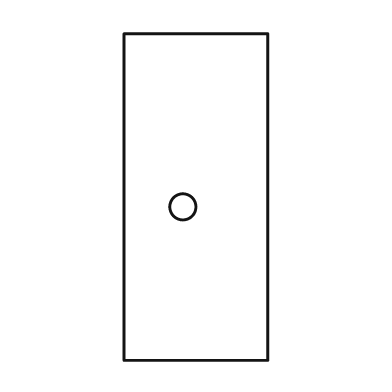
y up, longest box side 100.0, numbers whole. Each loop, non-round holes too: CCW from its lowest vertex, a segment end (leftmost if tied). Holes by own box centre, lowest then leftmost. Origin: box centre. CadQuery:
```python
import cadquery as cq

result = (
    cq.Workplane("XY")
    .moveTo(-22.0, -50.0)
    .lineTo(22.0, -50.0)
    .lineTo(22.0, 50.0)
    .lineTo(-22.0, 50.0)
    .close()
    .moveTo(-4.0, -3.0)
    .circle(4.0)
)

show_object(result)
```